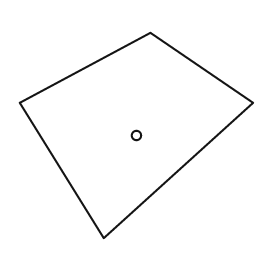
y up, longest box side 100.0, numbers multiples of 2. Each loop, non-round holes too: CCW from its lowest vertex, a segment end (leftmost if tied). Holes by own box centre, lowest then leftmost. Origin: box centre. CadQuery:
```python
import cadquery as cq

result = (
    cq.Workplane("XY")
    .moveTo(-14.0, -44.0)
    .lineTo(50.0, 14.0)
    .lineTo(6.0, 44.0)
    .lineTo(-50.0, 14.0)
    .close()
    .moveTo(0.0, 0.0)
    .circle(2.0)
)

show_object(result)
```